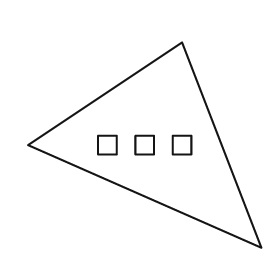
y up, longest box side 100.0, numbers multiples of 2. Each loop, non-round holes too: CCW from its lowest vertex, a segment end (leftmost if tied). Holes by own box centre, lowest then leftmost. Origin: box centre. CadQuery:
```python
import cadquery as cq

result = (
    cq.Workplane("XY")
    .moveTo(50.0, -44.0)
    .lineTo(16.0, 44.0)
    .lineTo(-50.0, 0.0)
    .close()
    .moveTo(-20.0, -4.0)
    .lineTo(-12.0, -4.0)
    .lineTo(-12.0, 4.0)
    .lineTo(-20.0, 4.0)
    .close()
    .moveTo(-4.0, -4.0)
    .lineTo(4.0, -4.0)
    .lineTo(4.0, 4.0)
    .lineTo(-4.0, 4.0)
    .close()
    .moveTo(12.0, -4.0)
    .lineTo(20.0, -4.0)
    .lineTo(20.0, 4.0)
    .lineTo(12.0, 4.0)
    .close()
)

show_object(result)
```